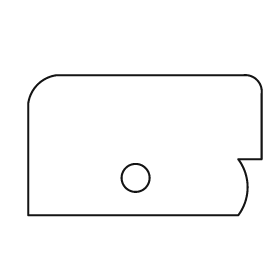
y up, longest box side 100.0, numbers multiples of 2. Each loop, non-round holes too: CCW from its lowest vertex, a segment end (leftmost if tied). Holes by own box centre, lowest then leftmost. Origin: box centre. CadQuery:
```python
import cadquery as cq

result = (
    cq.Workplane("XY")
    .moveTo(-50.0, -30.0)
    .lineTo(40.0, -30.0)
    .threePointArc((44.0, -18.0), (40.0, -6.0))
    .lineTo(50.0, -6.0)
    .lineTo(50.0, 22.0)
    .threePointArc((48.0, 28.0), (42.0, 30.0))
    .lineTo(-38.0, 30.0)
    .threePointArc((-46.0, 26.0), (-50.0, 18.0))
    .close()
    .moveTo(-4.0, -14.0)
    .circle(6.0)
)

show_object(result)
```